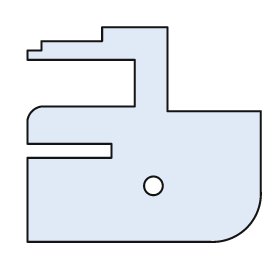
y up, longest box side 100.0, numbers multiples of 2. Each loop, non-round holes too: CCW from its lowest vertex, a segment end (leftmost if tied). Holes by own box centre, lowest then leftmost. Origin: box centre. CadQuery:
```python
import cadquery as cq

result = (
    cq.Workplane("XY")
    .moveTo(-50.0, -46.0)
    .lineTo(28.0, -46.0)
    .threePointArc((44.0, -40.0), (50.0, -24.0))
    .lineTo(50.0, 10.0)
    .lineTo(10.0, 10.0)
    .lineTo(10.0, 46.0)
    .lineTo(-18.0, 46.0)
    .lineTo(-18.0, 40.0)
    .lineTo(-44.0, 40.0)
    .lineTo(-44.0, 36.0)
    .lineTo(-50.0, 36.0)
    .lineTo(-50.0, 32.0)
    .lineTo(-4.0, 32.0)
    .lineTo(-4.0, 12.0)
    .lineTo(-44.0, 12.0)
    .threePointArc((-48.0, 10.0), (-50.0, 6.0))
    .lineTo(-50.0, -4.0)
    .lineTo(-14.0, -4.0)
    .lineTo(-14.0, -10.0)
    .lineTo(-50.0, -10.0)
    .close()
    .moveTo(4.0, -22.0)
    .circle(4.0)
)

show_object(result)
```